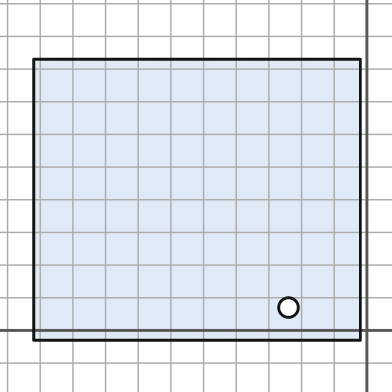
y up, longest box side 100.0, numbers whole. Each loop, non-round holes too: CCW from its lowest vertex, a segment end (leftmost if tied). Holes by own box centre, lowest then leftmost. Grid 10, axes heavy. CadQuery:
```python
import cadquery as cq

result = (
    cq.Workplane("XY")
    .moveTo(-102.0, -3.0)
    .lineTo(-2.0, -3.0)
    .lineTo(-2.0, 83.0)
    .lineTo(-102.0, 83.0)
    .close()
    .moveTo(-24.0, 7.0)
    .circle(3.0)
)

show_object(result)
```